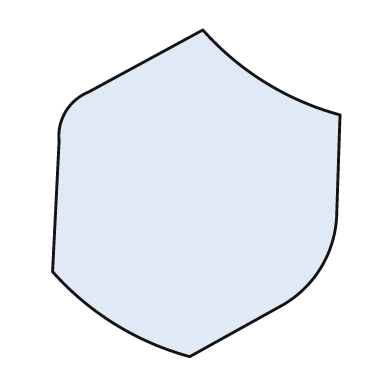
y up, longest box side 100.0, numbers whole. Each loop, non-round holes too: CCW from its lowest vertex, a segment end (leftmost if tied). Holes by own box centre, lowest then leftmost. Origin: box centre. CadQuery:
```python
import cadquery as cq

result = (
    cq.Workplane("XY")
    .moveTo(-2.0, -50.0)
    .lineTo(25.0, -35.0)
    .threePointArc((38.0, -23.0), (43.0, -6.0))
    .lineTo(44.0, 24.0)
    .threePointArc((21.0, 34.0), (2.0, 50.0))
    .lineTo(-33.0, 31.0)
    .threePointArc((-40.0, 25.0), (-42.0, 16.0))
    .lineTo(-44.0, -24.0)
    .threePointArc((-25.0, -40.0), (-2.0, -50.0))
    .close()
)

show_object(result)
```